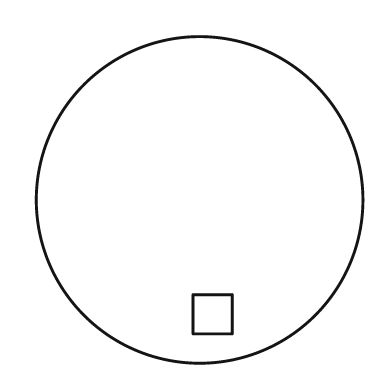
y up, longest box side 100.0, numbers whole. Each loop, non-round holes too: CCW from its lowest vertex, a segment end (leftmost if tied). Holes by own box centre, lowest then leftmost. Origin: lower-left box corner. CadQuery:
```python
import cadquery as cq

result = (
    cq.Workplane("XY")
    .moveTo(50.0, 50.0)
    .circle(50.0)
    .moveTo(48.0, 9.0)
    .lineTo(60.0, 9.0)
    .lineTo(60.0, 21.0)
    .lineTo(48.0, 21.0)
    .close()
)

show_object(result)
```